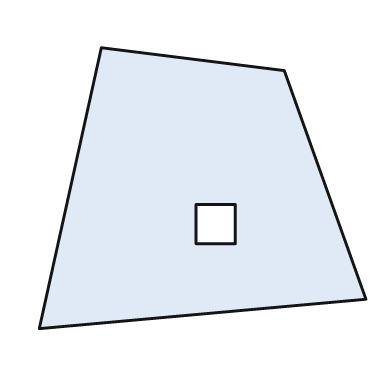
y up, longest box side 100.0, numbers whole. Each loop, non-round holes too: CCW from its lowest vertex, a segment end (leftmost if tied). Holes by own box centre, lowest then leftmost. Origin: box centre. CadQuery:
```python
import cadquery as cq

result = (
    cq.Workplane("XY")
    .moveTo(-50.0, -43.0)
    .lineTo(50.0, -34.0)
    .lineTo(25.0, 36.0)
    .lineTo(-31.0, 43.0)
    .close()
    .moveTo(-2.0, -17.0)
    .lineTo(10.0, -17.0)
    .lineTo(10.0, -5.0)
    .lineTo(-2.0, -5.0)
    .close()
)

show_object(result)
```